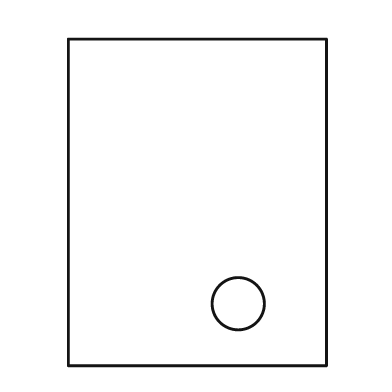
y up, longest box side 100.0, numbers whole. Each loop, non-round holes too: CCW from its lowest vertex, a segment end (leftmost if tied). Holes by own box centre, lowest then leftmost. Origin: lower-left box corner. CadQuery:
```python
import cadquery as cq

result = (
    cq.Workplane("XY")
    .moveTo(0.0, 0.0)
    .lineTo(79.0, 0.0)
    .lineTo(79.0, 100.0)
    .lineTo(0.0, 100.0)
    .close()
    .moveTo(52.0, 19.0)
    .circle(8.0)
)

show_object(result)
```